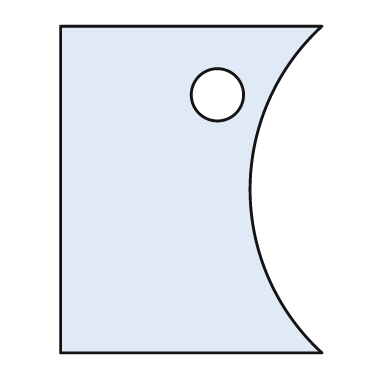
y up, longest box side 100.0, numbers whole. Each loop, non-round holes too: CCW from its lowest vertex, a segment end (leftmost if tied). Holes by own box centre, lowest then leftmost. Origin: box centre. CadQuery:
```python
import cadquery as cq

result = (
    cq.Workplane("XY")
    .moveTo(-40.0, -50.0)
    .lineTo(40.0, -50.0)
    .threePointArc((18.0, 0.0), (40.0, 50.0))
    .lineTo(-40.0, 50.0)
    .close()
    .moveTo(8.0, 29.0)
    .circle(8.0)
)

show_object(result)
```